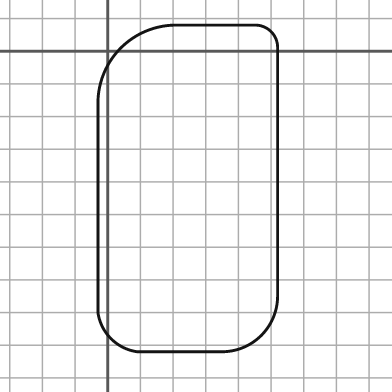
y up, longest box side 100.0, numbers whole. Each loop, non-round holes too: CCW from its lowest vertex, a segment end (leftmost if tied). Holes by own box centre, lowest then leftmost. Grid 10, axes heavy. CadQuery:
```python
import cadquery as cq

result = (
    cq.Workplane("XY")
    .moveTo(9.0, -92.0)
    .lineTo(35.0, -92.0)
    .threePointArc((47.0, -87.0), (52.0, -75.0))
    .lineTo(52.0, 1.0)
    .threePointArc((50.0, 6.0), (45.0, 8.0))
    .lineTo(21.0, 8.0)
    .threePointArc((4.0, 1.0), (-3.0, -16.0))
    .lineTo(-3.0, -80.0)
    .threePointArc((1.0, -88.0), (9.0, -92.0))
    .close()
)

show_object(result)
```